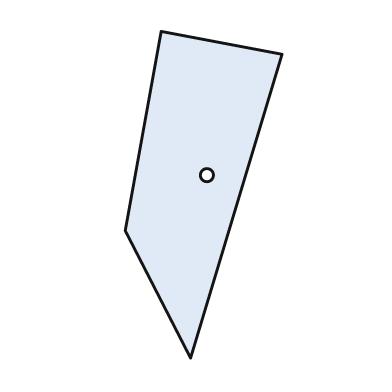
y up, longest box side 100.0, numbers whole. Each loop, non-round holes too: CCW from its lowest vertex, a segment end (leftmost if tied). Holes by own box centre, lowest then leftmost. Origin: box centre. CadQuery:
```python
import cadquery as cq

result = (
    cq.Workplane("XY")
    .moveTo(-4.0, -50.0)
    .lineTo(24.0, 43.0)
    .lineTo(-13.0, 50.0)
    .lineTo(-24.0, -11.0)
    .close()
    .moveTo(1.0, 6.0)
    .circle(2.0)
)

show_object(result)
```